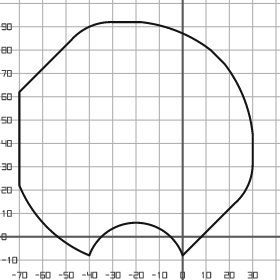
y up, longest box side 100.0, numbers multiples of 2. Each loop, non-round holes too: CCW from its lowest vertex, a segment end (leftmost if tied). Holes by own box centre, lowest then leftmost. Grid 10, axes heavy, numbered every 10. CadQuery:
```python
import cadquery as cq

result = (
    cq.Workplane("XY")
    .moveTo(-40.0, -8.0)
    .threePointArc((-20.0, 6.0), (0.0, -8.0))
    .lineTo(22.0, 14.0)
    .threePointArc((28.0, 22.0), (30.0, 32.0))
    .lineTo(30.0, 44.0)
    .threePointArc((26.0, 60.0), (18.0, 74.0))
    .lineTo(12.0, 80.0)
    .threePointArc((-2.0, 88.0), (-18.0, 92.0))
    .lineTo(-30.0, 92.0)
    .threePointArc((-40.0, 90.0), (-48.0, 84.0))
    .lineTo(-70.0, 62.0)
    .lineTo(-70.0, 22.0)
    .threePointArc((-58.0, 4.0), (-40.0, -8.0))
    .close()
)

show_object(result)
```